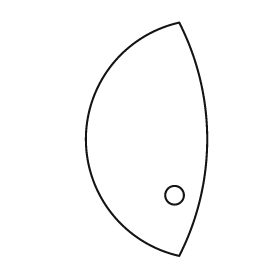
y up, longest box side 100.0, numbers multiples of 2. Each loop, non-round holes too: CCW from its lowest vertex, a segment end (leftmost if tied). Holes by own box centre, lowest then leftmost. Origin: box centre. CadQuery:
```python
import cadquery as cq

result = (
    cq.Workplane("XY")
    .moveTo(14.0, -50.0)
    .threePointArc((26.0, 0.0), (14.0, 50.0))
    .threePointArc((-26.0, 0.0), (14.0, -50.0))
    .close()
    .moveTo(12.0, -24.0)
    .circle(4.0)
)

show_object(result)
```